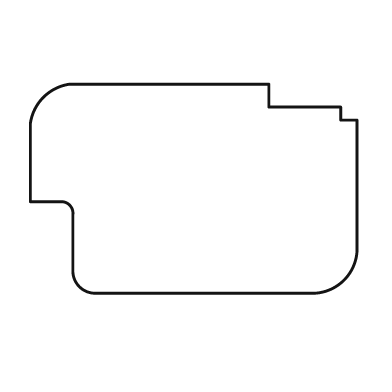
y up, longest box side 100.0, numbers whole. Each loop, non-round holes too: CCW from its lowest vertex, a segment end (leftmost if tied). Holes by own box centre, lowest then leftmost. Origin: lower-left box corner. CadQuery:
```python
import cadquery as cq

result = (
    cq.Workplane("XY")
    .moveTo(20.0, 0.0)
    .lineTo(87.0, 0.0)
    .threePointArc((96.0, 4.0), (100.0, 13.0))
    .lineTo(100.0, 53.0)
    .lineTo(95.0, 53.0)
    .lineTo(95.0, 57.0)
    .lineTo(73.0, 57.0)
    .lineTo(73.0, 64.0)
    .lineTo(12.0, 64.0)
    .threePointArc((4.0, 60.0), (0.0, 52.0))
    .lineTo(0.0, 28.0)
    .lineTo(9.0, 28.0)
    .threePointArc((12.0, 27.0), (13.0, 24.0))
    .lineTo(13.0, 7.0)
    .threePointArc((15.0, 2.0), (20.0, 0.0))
    .close()
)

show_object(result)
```